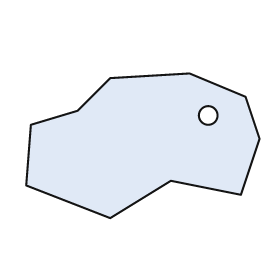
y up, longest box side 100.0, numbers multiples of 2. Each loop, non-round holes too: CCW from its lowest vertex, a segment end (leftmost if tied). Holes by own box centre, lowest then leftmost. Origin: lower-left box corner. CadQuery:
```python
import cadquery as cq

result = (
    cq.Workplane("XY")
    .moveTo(36.0, 0.0)
    .lineTo(62.0, 16.0)
    .lineTo(92.0, 10.0)
    .lineTo(100.0, 34.0)
    .lineTo(94.0, 52.0)
    .lineTo(70.0, 62.0)
    .lineTo(36.0, 60.0)
    .lineTo(22.0, 46.0)
    .lineTo(2.0, 40.0)
    .lineTo(0.0, 14.0)
    .close()
    .moveTo(78.0, 44.0)
    .circle(4.0)
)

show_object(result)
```